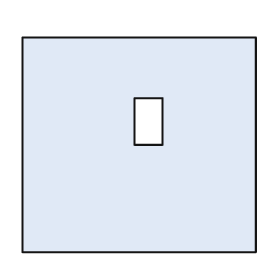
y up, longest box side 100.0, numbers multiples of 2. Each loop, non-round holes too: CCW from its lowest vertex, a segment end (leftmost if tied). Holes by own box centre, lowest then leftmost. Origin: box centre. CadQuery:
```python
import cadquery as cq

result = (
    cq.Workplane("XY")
    .moveTo(-50.0, -46.0)
    .lineTo(50.0, -46.0)
    .lineTo(50.0, 46.0)
    .lineTo(-50.0, 46.0)
    .close()
    .moveTo(-2.0, 0.0)
    .lineTo(10.0, 0.0)
    .lineTo(10.0, 20.0)
    .lineTo(-2.0, 20.0)
    .close()
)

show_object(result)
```